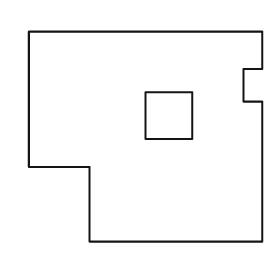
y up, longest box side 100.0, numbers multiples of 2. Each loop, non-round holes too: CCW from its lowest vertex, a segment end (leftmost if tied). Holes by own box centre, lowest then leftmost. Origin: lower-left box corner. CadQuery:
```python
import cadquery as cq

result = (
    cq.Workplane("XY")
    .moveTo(26.0, 0.0)
    .lineTo(100.0, 0.0)
    .lineTo(100.0, 60.0)
    .lineTo(92.0, 60.0)
    .lineTo(92.0, 74.0)
    .lineTo(100.0, 74.0)
    .lineTo(100.0, 90.0)
    .lineTo(0.0, 90.0)
    .lineTo(0.0, 32.0)
    .lineTo(26.0, 32.0)
    .close()
    .moveTo(50.0, 44.0)
    .lineTo(70.0, 44.0)
    .lineTo(70.0, 64.0)
    .lineTo(50.0, 64.0)
    .close()
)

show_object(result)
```